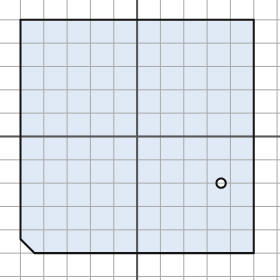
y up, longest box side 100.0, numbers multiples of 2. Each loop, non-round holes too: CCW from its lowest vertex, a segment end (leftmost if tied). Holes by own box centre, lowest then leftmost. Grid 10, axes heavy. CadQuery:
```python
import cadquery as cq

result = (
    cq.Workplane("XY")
    .moveTo(-44.0, -50.0)
    .lineTo(50.0, -50.0)
    .lineTo(50.0, 50.0)
    .lineTo(-50.0, 50.0)
    .lineTo(-50.0, -44.0)
    .close()
    .moveTo(36.0, -20.0)
    .circle(2.0)
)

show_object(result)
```